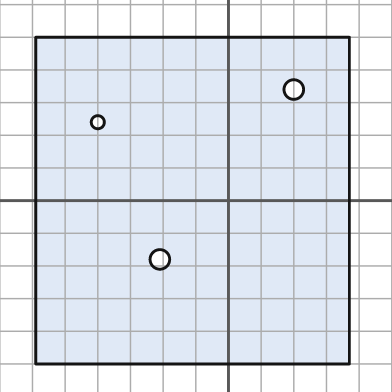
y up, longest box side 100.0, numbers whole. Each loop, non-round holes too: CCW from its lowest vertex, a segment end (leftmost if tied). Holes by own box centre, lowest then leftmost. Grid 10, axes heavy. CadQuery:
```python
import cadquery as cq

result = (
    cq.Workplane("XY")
    .moveTo(-59.0, -50.0)
    .lineTo(37.0, -50.0)
    .lineTo(37.0, 50.0)
    .lineTo(-59.0, 50.0)
    .close()
    .moveTo(-21.0, -18.0)
    .circle(3.0)
    .moveTo(-40.0, 24.0)
    .circle(2.0)
    .moveTo(20.0, 34.0)
    .circle(3.0)
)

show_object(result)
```